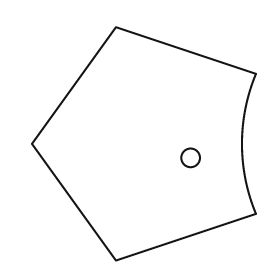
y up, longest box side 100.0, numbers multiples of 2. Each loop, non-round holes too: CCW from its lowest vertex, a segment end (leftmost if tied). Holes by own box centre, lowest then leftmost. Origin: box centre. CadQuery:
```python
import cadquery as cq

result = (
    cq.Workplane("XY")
    .moveTo(-12.0, -50.0)
    .lineTo(48.0, -30.0)
    .threePointArc((42.0, 0.0), (48.0, 30.0))
    .lineTo(-12.0, 50.0)
    .lineTo(-48.0, 0.0)
    .close()
    .moveTo(20.0, -6.0)
    .circle(4.0)
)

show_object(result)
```